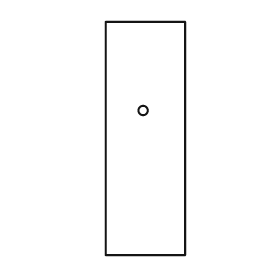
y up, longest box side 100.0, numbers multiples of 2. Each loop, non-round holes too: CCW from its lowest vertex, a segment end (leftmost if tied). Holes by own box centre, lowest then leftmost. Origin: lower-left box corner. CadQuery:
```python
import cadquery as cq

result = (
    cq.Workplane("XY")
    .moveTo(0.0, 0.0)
    .lineTo(34.0, 0.0)
    .lineTo(34.0, 100.0)
    .lineTo(0.0, 100.0)
    .close()
    .moveTo(16.0, 62.0)
    .circle(2.0)
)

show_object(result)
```